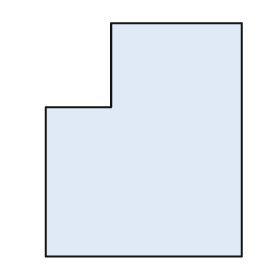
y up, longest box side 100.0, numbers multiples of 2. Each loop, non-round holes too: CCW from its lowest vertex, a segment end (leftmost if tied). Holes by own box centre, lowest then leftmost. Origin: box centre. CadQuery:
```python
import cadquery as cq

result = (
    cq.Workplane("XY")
    .moveTo(-42.0, -50.0)
    .lineTo(42.0, -50.0)
    .lineTo(42.0, 50.0)
    .lineTo(-14.0, 50.0)
    .lineTo(-14.0, 14.0)
    .lineTo(-42.0, 14.0)
    .close()
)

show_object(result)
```